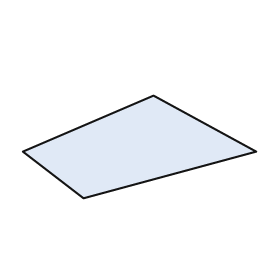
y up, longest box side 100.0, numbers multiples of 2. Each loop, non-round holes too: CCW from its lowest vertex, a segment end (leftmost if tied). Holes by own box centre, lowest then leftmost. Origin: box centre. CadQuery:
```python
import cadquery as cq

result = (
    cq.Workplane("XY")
    .moveTo(-24.0, -22.0)
    .lineTo(50.0, -2.0)
    .lineTo(6.0, 22.0)
    .lineTo(-50.0, -2.0)
    .close()
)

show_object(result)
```